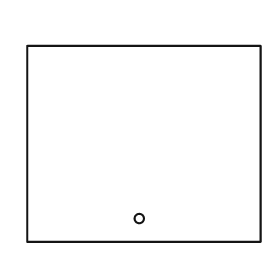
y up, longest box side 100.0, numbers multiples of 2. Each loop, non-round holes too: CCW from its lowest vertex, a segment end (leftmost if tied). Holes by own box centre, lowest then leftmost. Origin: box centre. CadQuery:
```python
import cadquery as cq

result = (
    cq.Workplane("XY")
    .moveTo(-50.0, -42.0)
    .lineTo(50.0, -42.0)
    .lineTo(50.0, 42.0)
    .lineTo(-50.0, 42.0)
    .close()
    .moveTo(-2.0, -32.0)
    .circle(2.0)
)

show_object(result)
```